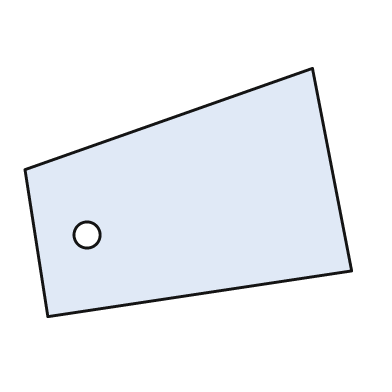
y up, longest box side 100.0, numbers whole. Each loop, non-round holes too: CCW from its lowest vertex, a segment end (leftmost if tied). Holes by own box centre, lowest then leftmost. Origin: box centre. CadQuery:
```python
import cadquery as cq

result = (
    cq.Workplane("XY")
    .moveTo(-43.0, -38.0)
    .lineTo(50.0, -24.0)
    .lineTo(38.0, 38.0)
    .lineTo(-50.0, 7.0)
    .close()
    .moveTo(-31.0, -13.0)
    .circle(4.0)
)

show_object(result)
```